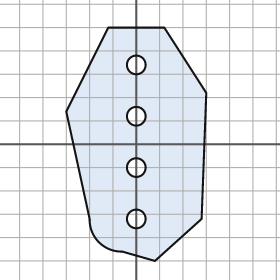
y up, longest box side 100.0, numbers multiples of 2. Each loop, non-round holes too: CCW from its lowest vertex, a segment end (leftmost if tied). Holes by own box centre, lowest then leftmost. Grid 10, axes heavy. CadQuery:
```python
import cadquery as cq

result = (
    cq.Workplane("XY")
    .moveTo(8.0, -50.0)
    .lineTo(28.0, -32.0)
    .lineTo(30.0, 22.0)
    .lineTo(12.0, 50.0)
    .lineTo(-12.0, 50.0)
    .lineTo(-30.0, 14.0)
    .lineTo(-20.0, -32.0)
    .threePointArc((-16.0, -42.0), (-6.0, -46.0))
    .close()
    .moveTo(0.0, -32.0)
    .circle(4.0)
    .moveTo(0.0, -10.0)
    .circle(4.0)
    .moveTo(0.0, 12.0)
    .circle(4.0)
    .moveTo(0.0, 34.0)
    .circle(4.0)
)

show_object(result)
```